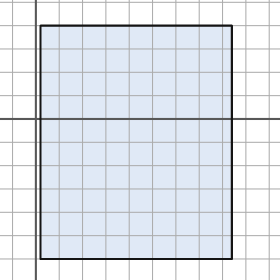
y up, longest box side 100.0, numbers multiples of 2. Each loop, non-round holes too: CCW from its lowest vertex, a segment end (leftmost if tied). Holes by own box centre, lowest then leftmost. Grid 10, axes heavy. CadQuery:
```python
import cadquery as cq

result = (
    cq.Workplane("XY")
    .moveTo(2.0, -60.0)
    .lineTo(84.0, -60.0)
    .lineTo(84.0, 40.0)
    .lineTo(2.0, 40.0)
    .close()
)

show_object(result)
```